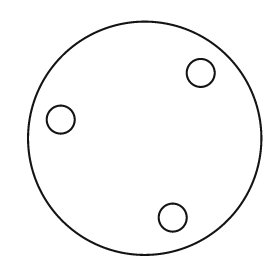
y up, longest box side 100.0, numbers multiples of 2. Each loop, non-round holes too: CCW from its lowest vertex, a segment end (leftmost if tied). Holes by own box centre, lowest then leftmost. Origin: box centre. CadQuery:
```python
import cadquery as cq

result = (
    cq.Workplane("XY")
    .moveTo(0.0, 0.0)
    .circle(50.0)
    .moveTo(12.0, -34.0)
    .circle(6.0)
    .moveTo(-36.0, 8.0)
    .circle(6.0)
    .moveTo(24.0, 28.0)
    .circle(6.0)
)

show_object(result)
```